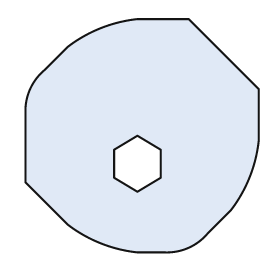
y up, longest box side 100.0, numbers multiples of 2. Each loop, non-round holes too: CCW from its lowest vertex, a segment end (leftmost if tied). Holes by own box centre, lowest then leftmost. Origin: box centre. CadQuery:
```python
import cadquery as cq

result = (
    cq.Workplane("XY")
    .moveTo(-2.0, -50.0)
    .lineTo(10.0, -50.0)
    .threePointArc((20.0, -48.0), (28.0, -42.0))
    .lineTo(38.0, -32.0)
    .threePointArc((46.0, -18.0), (50.0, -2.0))
    .lineTo(50.0, 20.0)
    .lineTo(20.0, 50.0)
    .lineTo(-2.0, 50.0)
    .threePointArc((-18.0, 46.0), (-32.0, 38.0))
    .lineTo(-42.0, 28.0)
    .threePointArc((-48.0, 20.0), (-50.0, 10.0))
    .lineTo(-50.0, -20.0)
    .lineTo(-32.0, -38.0)
    .threePointArc((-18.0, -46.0), (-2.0, -50.0))
    .close()
    .moveTo(-2.0, -24.0)
    .lineTo(8.0, -18.0)
    .lineTo(8.0, -6.0)
    .lineTo(-2.0, 0.0)
    .lineTo(-12.0, -6.0)
    .lineTo(-12.0, -18.0)
    .close()
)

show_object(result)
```